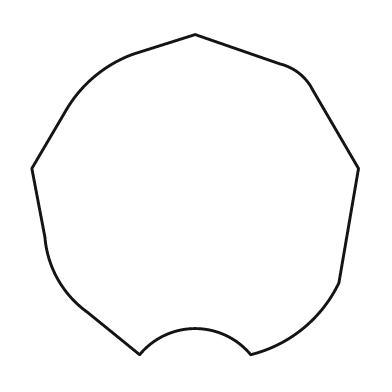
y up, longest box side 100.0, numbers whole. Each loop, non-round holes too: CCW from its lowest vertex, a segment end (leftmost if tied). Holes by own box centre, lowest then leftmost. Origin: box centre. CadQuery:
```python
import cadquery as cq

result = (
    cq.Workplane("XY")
    .moveTo(-17.0, -49.0)
    .threePointArc((0.0, -41.0), (17.0, -49.0))
    .threePointArc((33.0, -41.0), (44.0, -27.0))
    .lineTo(50.0, 8.0)
    .lineTo(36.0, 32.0)
    .threePointArc((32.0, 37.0), (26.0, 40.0))
    .lineTo(0.0, 49.0)
    .lineTo(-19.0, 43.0)
    .threePointArc((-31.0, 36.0), (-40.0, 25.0))
    .lineTo(-50.0, 8.0)
    .lineTo(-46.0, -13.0)
    .threePointArc((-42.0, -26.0), (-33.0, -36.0))
    .close()
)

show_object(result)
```